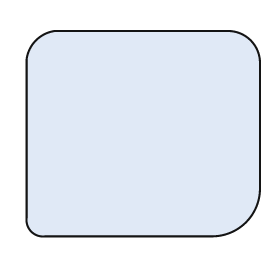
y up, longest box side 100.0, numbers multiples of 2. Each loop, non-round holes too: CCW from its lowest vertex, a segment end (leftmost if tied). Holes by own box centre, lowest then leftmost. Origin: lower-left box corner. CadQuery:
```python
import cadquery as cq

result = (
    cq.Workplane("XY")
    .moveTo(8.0, 0.0)
    .lineTo(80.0, 0.0)
    .threePointArc((94.0, 6.0), (100.0, 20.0))
    .lineTo(100.0, 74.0)
    .threePointArc((96.0, 84.0), (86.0, 88.0))
    .lineTo(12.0, 88.0)
    .threePointArc((4.0, 84.0), (0.0, 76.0))
    .lineTo(0.0, 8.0)
    .threePointArc((2.0, 2.0), (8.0, 0.0))
    .close()
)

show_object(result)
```